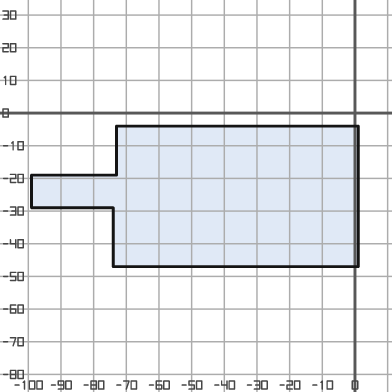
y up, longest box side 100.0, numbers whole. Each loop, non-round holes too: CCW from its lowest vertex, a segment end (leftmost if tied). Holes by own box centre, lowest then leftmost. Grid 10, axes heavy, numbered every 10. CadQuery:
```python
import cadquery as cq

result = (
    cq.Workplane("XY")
    .moveTo(-74.0, -47.0)
    .lineTo(1.0, -47.0)
    .lineTo(1.0, -4.0)
    .lineTo(-73.0, -4.0)
    .lineTo(-73.0, -19.0)
    .lineTo(-99.0, -19.0)
    .lineTo(-99.0, -29.0)
    .lineTo(-74.0, -29.0)
    .close()
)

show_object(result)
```